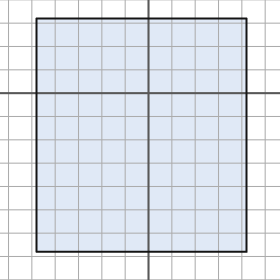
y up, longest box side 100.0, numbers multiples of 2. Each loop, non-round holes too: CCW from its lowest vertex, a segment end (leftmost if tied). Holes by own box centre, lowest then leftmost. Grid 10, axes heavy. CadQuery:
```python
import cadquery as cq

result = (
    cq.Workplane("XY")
    .moveTo(-48.0, -68.0)
    .lineTo(42.0, -68.0)
    .lineTo(42.0, 32.0)
    .lineTo(-48.0, 32.0)
    .close()
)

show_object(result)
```